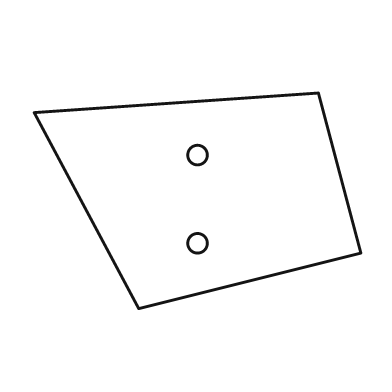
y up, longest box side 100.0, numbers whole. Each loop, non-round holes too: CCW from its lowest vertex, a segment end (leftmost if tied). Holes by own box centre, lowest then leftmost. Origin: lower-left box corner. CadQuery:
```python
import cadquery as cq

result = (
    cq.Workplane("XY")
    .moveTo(32.0, 0.0)
    .lineTo(100.0, 17.0)
    .lineTo(87.0, 66.0)
    .lineTo(0.0, 60.0)
    .close()
    .moveTo(50.0, 20.0)
    .circle(3.0)
    .moveTo(50.0, 47.0)
    .circle(3.0)
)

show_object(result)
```